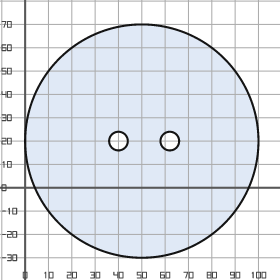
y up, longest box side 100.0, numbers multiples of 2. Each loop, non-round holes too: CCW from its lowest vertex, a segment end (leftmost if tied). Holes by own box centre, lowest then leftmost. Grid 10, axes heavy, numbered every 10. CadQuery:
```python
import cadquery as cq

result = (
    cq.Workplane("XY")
    .moveTo(50.0, 20.0)
    .circle(50.0)
    .moveTo(40.0, 20.0)
    .circle(4.0)
    .moveTo(62.0, 20.0)
    .circle(4.0)
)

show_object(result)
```